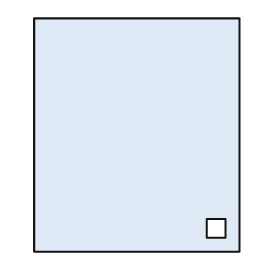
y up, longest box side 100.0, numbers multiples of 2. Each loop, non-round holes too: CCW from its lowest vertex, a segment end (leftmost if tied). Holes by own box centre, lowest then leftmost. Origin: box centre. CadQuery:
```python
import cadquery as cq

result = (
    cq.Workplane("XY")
    .moveTo(-44.0, -50.0)
    .lineTo(44.0, -50.0)
    .lineTo(44.0, 50.0)
    .lineTo(-44.0, 50.0)
    .close()
    .moveTo(30.0, -44.0)
    .lineTo(38.0, -44.0)
    .lineTo(38.0, -36.0)
    .lineTo(30.0, -36.0)
    .close()
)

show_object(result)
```